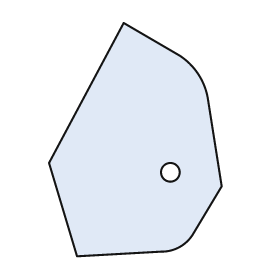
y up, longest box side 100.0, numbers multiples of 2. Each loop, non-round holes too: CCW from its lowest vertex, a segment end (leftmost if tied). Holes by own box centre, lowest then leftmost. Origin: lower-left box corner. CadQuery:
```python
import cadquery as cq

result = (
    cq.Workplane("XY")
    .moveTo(12.0, 0.0)
    .lineTo(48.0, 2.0)
    .threePointArc((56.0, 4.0), (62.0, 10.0))
    .lineTo(74.0, 30.0)
    .lineTo(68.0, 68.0)
    .threePointArc((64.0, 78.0), (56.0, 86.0))
    .lineTo(32.0, 100.0)
    .lineTo(0.0, 40.0)
    .close()
    .moveTo(52.0, 36.0)
    .circle(4.0)
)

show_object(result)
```